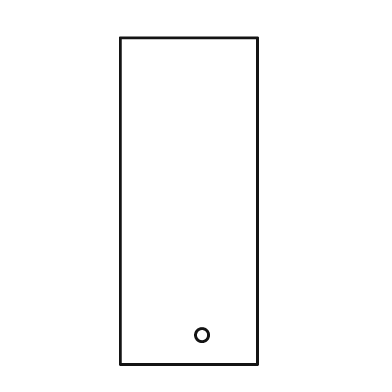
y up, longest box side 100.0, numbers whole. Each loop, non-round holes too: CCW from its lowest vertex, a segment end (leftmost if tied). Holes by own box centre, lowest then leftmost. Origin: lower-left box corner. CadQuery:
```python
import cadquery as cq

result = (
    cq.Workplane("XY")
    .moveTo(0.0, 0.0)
    .lineTo(42.0, 0.0)
    .lineTo(42.0, 100.0)
    .lineTo(0.0, 100.0)
    .close()
    .moveTo(25.0, 9.0)
    .circle(2.0)
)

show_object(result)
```